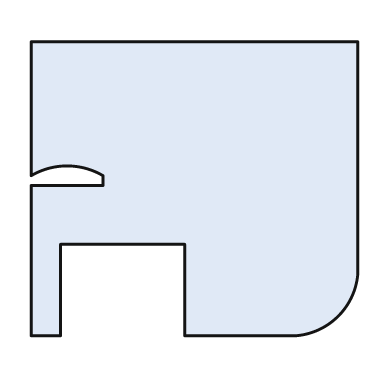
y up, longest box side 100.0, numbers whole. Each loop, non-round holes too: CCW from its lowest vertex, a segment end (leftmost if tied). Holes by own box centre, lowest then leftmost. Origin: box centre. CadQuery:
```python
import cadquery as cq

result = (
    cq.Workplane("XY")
    .moveTo(-50.0, -45.0)
    .lineTo(-41.0, -45.0)
    .lineTo(-41.0, -17.0)
    .lineTo(-3.0, -17.0)
    .lineTo(-3.0, -45.0)
    .lineTo(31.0, -45.0)
    .threePointArc((44.0, -39.0), (50.0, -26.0))
    .lineTo(50.0, 45.0)
    .lineTo(-50.0, 45.0)
    .lineTo(-50.0, 4.0)
    .threePointArc((-39.0, 7.0), (-28.0, 4.0))
    .lineTo(-28.0, 1.0)
    .lineTo(-50.0, 1.0)
    .close()
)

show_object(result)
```